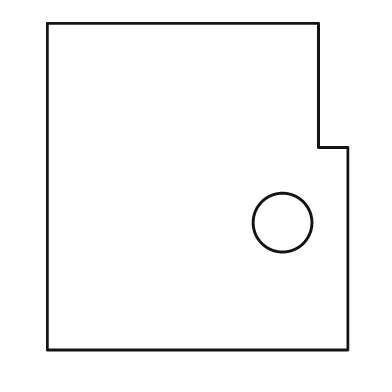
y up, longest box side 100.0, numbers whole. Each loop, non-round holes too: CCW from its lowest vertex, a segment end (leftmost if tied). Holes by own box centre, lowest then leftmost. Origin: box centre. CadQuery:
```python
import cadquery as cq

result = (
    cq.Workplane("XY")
    .moveTo(-46.0, -50.0)
    .lineTo(46.0, -50.0)
    .lineTo(46.0, 12.0)
    .lineTo(37.0, 12.0)
    .lineTo(37.0, 50.0)
    .lineTo(-46.0, 50.0)
    .close()
    .moveTo(26.0, -11.0)
    .circle(9.0)
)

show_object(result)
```